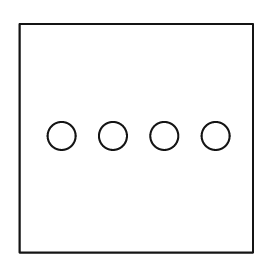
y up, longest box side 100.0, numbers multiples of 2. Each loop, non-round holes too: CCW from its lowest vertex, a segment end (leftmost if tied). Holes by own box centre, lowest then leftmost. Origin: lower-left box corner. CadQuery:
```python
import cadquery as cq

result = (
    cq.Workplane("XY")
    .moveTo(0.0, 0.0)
    .lineTo(100.0, 0.0)
    .lineTo(100.0, 98.0)
    .lineTo(0.0, 98.0)
    .close()
    .moveTo(18.0, 50.0)
    .circle(6.0)
    .moveTo(40.0, 50.0)
    .circle(6.0)
    .moveTo(62.0, 50.0)
    .circle(6.0)
    .moveTo(84.0, 50.0)
    .circle(6.0)
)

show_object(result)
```